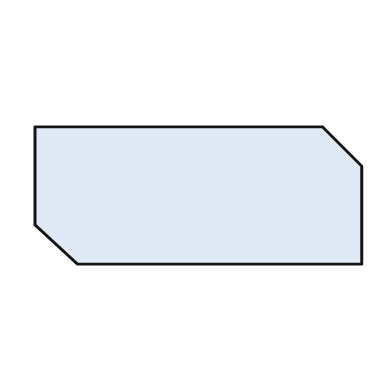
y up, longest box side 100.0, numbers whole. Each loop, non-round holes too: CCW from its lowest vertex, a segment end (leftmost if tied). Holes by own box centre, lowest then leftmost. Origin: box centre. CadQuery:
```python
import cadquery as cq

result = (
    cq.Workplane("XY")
    .moveTo(-37.0, -21.0)
    .lineTo(50.0, -21.0)
    .lineTo(50.0, 9.0)
    .lineTo(38.0, 21.0)
    .lineTo(-50.0, 21.0)
    .lineTo(-50.0, -9.0)
    .close()
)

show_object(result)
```